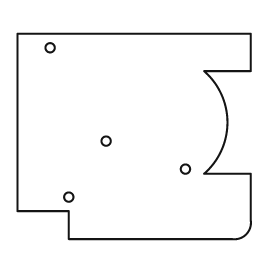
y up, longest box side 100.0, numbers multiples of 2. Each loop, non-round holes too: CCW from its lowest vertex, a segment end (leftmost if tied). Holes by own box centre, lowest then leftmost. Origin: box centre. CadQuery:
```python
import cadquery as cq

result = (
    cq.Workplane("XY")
    .moveTo(-28.0, -44.0)
    .lineTo(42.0, -44.0)
    .threePointArc((48.0, -42.0), (50.0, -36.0))
    .lineTo(50.0, -16.0)
    .lineTo(30.0, -16.0)
    .threePointArc((40.0, 6.0), (30.0, 28.0))
    .lineTo(50.0, 28.0)
    .lineTo(50.0, 44.0)
    .lineTo(-50.0, 44.0)
    .lineTo(-50.0, -32.0)
    .lineTo(-28.0, -32.0)
    .close()
    .moveTo(-28.0, -26.0)
    .circle(2.0)
    .moveTo(22.0, -14.0)
    .circle(2.0)
    .moveTo(-12.0, -2.0)
    .circle(2.0)
    .moveTo(-36.0, 38.0)
    .circle(2.0)
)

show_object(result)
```